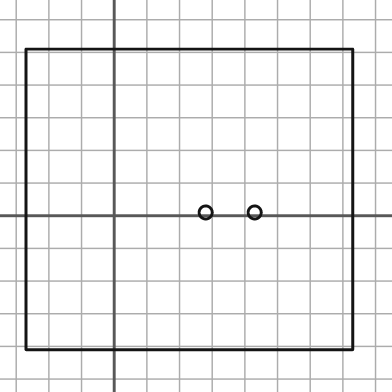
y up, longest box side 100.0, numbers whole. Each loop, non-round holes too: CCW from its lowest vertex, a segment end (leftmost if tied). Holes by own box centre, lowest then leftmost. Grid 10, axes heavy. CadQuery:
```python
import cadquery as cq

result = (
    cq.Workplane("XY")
    .moveTo(-27.0, -41.0)
    .lineTo(73.0, -41.0)
    .lineTo(73.0, 51.0)
    .lineTo(-27.0, 51.0)
    .close()
    .moveTo(28.0, 1.0)
    .circle(2.0)
    .moveTo(43.0, 1.0)
    .circle(2.0)
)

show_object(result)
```